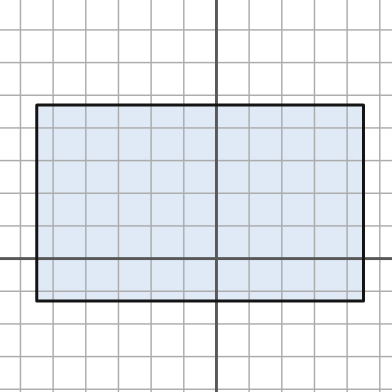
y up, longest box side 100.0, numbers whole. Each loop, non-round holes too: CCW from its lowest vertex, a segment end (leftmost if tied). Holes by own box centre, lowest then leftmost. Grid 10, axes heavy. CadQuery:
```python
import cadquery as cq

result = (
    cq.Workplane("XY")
    .moveTo(-55.0, -13.0)
    .lineTo(45.0, -13.0)
    .lineTo(45.0, 47.0)
    .lineTo(-55.0, 47.0)
    .close()
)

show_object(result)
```